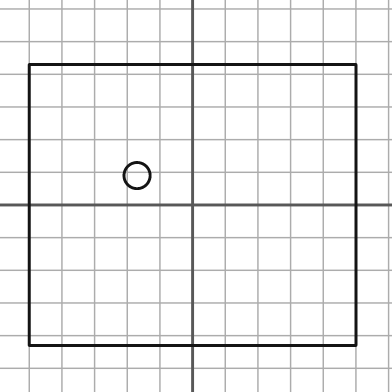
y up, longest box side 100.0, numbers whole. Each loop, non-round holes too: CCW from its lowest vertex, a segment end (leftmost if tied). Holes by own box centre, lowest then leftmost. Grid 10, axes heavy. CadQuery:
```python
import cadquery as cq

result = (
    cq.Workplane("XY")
    .moveTo(-50.0, -43.0)
    .lineTo(50.0, -43.0)
    .lineTo(50.0, 43.0)
    .lineTo(-50.0, 43.0)
    .close()
    .moveTo(-17.0, 9.0)
    .circle(4.0)
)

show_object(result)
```